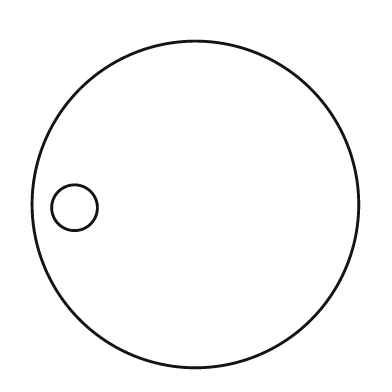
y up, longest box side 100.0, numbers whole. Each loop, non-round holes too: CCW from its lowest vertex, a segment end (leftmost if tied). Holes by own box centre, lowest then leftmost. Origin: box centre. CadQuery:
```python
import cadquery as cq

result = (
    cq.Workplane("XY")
    .moveTo(0.0, 0.0)
    .circle(50.0)
    .moveTo(-37.0, -1.0)
    .circle(7.0)
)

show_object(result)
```